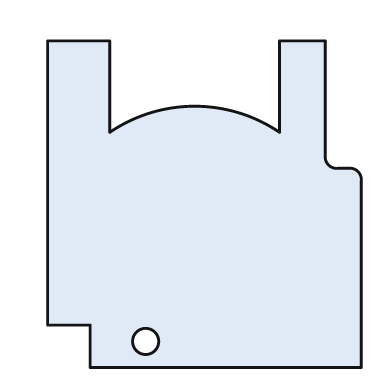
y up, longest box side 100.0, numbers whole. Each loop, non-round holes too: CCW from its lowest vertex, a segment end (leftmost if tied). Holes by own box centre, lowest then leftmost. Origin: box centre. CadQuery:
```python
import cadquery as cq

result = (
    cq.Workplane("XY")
    .moveTo(-35.0, -50.0)
    .lineTo(48.0, -50.0)
    .lineTo(48.0, 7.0)
    .threePointArc((47.0, 10.0), (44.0, 11.0))
    .lineTo(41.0, 11.0)
    .threePointArc((38.0, 12.0), (37.0, 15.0))
    .lineTo(37.0, 50.0)
    .lineTo(23.0, 50.0)
    .lineTo(23.0, 22.0)
    .threePointArc((-3.0, 30.0), (-29.0, 22.0))
    .lineTo(-29.0, 50.0)
    .lineTo(-48.0, 50.0)
    .lineTo(-48.0, -37.0)
    .lineTo(-35.0, -37.0)
    .close()
    .moveTo(-18.0, -42.0)
    .circle(4.0)
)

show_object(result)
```